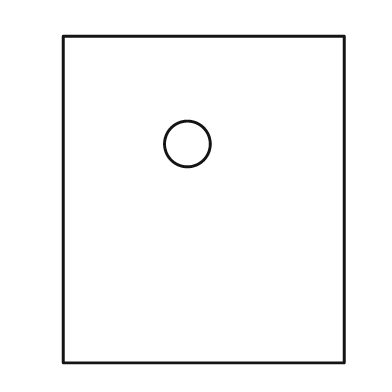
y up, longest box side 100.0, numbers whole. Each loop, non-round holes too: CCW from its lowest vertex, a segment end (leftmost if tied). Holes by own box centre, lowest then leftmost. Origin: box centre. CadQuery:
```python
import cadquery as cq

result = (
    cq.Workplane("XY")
    .moveTo(-43.0, -50.0)
    .lineTo(43.0, -50.0)
    .lineTo(43.0, 50.0)
    .lineTo(-43.0, 50.0)
    .close()
    .moveTo(-5.0, 17.0)
    .circle(7.0)
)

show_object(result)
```